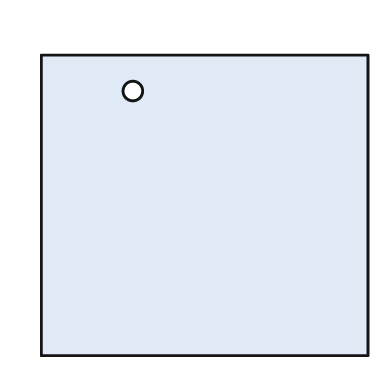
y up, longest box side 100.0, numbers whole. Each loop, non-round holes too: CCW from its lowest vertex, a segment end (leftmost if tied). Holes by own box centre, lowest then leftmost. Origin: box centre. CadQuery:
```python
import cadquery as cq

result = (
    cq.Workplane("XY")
    .moveTo(-50.0, -46.0)
    .lineTo(50.0, -46.0)
    .lineTo(50.0, 46.0)
    .lineTo(-50.0, 46.0)
    .close()
    .moveTo(-22.0, 35.0)
    .circle(3.0)
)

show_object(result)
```